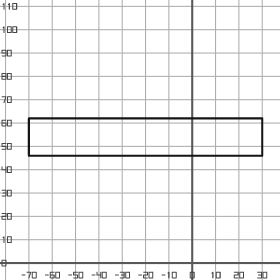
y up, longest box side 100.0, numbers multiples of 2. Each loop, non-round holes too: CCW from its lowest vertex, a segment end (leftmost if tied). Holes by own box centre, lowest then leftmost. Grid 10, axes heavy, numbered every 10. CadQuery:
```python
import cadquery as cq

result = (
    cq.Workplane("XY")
    .moveTo(-70.0, 46.0)
    .lineTo(30.0, 46.0)
    .lineTo(30.0, 62.0)
    .lineTo(-70.0, 62.0)
    .close()
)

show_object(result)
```